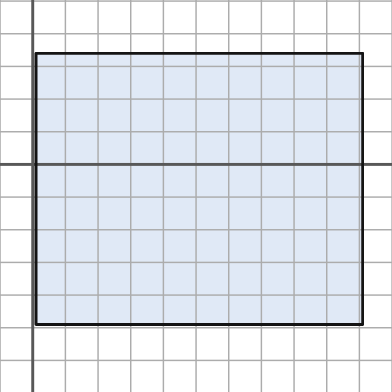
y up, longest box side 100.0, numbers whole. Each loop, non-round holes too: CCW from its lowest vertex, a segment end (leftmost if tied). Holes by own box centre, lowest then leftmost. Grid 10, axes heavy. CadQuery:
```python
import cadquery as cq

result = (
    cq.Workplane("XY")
    .moveTo(1.0, -49.0)
    .lineTo(101.0, -49.0)
    .lineTo(101.0, 34.0)
    .lineTo(1.0, 34.0)
    .close()
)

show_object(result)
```